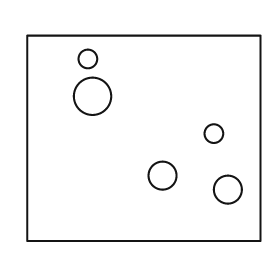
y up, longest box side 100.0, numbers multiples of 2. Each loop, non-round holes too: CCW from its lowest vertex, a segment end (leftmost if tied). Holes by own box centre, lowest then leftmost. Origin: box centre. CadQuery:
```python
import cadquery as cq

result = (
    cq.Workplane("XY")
    .moveTo(-50.0, -44.0)
    .lineTo(50.0, -44.0)
    .lineTo(50.0, 44.0)
    .lineTo(-50.0, 44.0)
    .close()
    .moveTo(36.0, -22.0)
    .circle(6.0)
    .moveTo(8.0, -16.0)
    .circle(6.0)
    .moveTo(30.0, 2.0)
    .circle(4.0)
    .moveTo(-22.0, 18.0)
    .circle(8.0)
    .moveTo(-24.0, 34.0)
    .circle(4.0)
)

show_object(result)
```